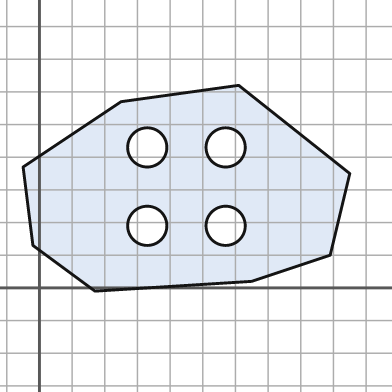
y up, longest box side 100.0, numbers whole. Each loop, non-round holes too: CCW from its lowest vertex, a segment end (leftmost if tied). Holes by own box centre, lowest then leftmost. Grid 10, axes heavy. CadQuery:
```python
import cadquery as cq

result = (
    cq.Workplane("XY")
    .moveTo(17.0, -1.0)
    .lineTo(65.0, 2.0)
    .lineTo(89.0, 10.0)
    .lineTo(95.0, 35.0)
    .lineTo(61.0, 62.0)
    .lineTo(25.0, 57.0)
    .lineTo(-5.0, 37.0)
    .lineTo(-2.0, 13.0)
    .close()
    .moveTo(33.0, 19.0)
    .circle(6.0)
    .moveTo(57.0, 19.0)
    .circle(6.0)
    .moveTo(33.0, 43.0)
    .circle(6.0)
    .moveTo(57.0, 43.0)
    .circle(6.0)
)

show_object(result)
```